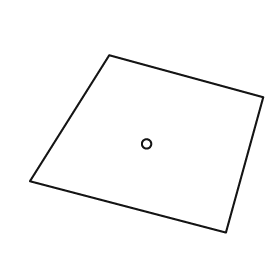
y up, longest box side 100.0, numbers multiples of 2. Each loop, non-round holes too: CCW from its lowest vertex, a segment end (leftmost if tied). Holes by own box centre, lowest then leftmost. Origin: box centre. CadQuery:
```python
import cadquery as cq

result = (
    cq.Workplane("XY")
    .moveTo(34.0, -38.0)
    .lineTo(50.0, 20.0)
    .lineTo(-16.0, 38.0)
    .lineTo(-50.0, -16.0)
    .close()
    .moveTo(0.0, 0.0)
    .circle(2.0)
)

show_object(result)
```